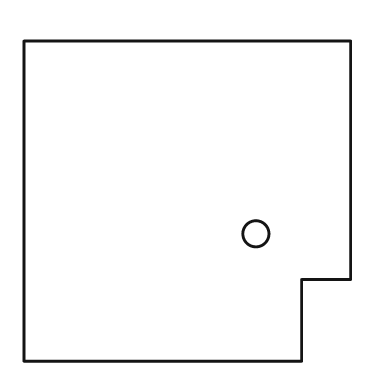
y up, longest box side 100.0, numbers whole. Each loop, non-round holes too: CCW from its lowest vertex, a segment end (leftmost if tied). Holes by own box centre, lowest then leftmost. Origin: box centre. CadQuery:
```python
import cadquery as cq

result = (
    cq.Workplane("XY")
    .moveTo(-50.0, -49.0)
    .lineTo(35.0, -49.0)
    .lineTo(35.0, -24.0)
    .lineTo(50.0, -24.0)
    .lineTo(50.0, 49.0)
    .lineTo(-50.0, 49.0)
    .close()
    .moveTo(21.0, -10.0)
    .circle(4.0)
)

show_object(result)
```